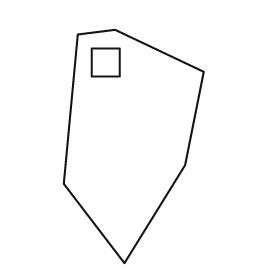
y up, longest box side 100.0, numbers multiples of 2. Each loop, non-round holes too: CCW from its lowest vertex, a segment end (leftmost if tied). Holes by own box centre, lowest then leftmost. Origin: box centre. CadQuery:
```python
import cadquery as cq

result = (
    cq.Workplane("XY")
    .moveTo(-4.0, -50.0)
    .lineTo(22.0, -8.0)
    .lineTo(30.0, 32.0)
    .lineTo(-8.0, 50.0)
    .lineTo(-24.0, 48.0)
    .lineTo(-30.0, -16.0)
    .close()
    .moveTo(-18.0, 30.0)
    .lineTo(-6.0, 30.0)
    .lineTo(-6.0, 42.0)
    .lineTo(-18.0, 42.0)
    .close()
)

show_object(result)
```